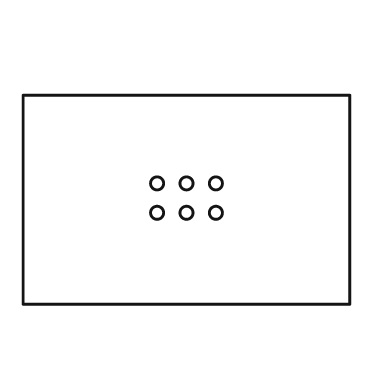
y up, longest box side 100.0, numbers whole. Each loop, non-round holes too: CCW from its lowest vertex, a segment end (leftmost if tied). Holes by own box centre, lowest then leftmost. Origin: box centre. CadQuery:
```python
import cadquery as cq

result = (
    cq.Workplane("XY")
    .moveTo(-50.0, -32.0)
    .lineTo(50.0, -32.0)
    .lineTo(50.0, 32.0)
    .lineTo(-50.0, 32.0)
    .close()
    .moveTo(-9.0, -4.0)
    .circle(2.0)
    .moveTo(0.0, -4.0)
    .circle(2.0)
    .moveTo(9.0, -4.0)
    .circle(2.0)
    .moveTo(-9.0, 5.0)
    .circle(2.0)
    .moveTo(0.0, 5.0)
    .circle(2.0)
    .moveTo(9.0, 5.0)
    .circle(2.0)
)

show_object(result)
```